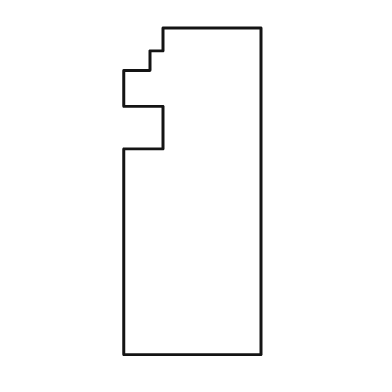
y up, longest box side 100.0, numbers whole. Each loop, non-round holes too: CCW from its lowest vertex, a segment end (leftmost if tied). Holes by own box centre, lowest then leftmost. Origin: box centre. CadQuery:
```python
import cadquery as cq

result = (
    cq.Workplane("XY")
    .moveTo(-21.0, -50.0)
    .lineTo(21.0, -50.0)
    .lineTo(21.0, 50.0)
    .lineTo(-9.0, 50.0)
    .lineTo(-9.0, 43.0)
    .lineTo(-13.0, 43.0)
    .lineTo(-13.0, 37.0)
    .lineTo(-21.0, 37.0)
    .lineTo(-21.0, 26.0)
    .lineTo(-9.0, 26.0)
    .lineTo(-9.0, 13.0)
    .lineTo(-21.0, 13.0)
    .close()
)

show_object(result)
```